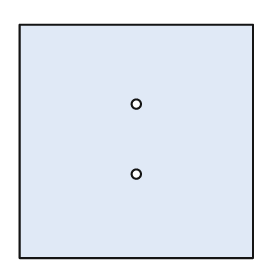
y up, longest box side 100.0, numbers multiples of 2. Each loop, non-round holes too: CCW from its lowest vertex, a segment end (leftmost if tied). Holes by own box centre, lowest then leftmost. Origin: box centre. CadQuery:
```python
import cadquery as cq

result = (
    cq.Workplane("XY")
    .moveTo(-50.0, -50.0)
    .lineTo(50.0, -50.0)
    .lineTo(50.0, 50.0)
    .lineTo(-50.0, 50.0)
    .close()
    .moveTo(0.0, -14.0)
    .circle(2.0)
    .moveTo(0.0, 16.0)
    .circle(2.0)
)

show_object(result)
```